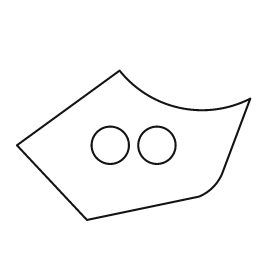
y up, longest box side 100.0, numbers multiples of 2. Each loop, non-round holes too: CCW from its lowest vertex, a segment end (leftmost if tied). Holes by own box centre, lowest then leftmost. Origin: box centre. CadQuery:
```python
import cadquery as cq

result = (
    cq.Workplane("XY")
    .moveTo(-20.0, -32.0)
    .lineTo(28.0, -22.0)
    .threePointArc((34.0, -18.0), (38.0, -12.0))
    .lineTo(50.0, 20.0)
    .threePointArc((20.0, 16.0), (-6.0, 32.0))
    .lineTo(-50.0, 0.0)
    .close()
    .moveTo(-10.0, 0.0)
    .circle(8.0)
    .moveTo(10.0, 0.0)
    .circle(8.0)
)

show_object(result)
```